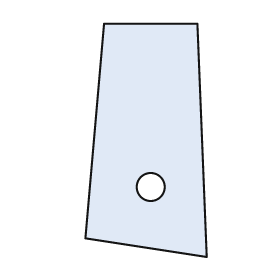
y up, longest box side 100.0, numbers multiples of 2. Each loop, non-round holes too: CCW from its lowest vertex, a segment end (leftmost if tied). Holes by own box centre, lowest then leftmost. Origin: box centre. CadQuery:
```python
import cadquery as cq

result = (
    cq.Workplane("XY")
    .moveTo(26.0, -50.0)
    .lineTo(22.0, 50.0)
    .lineTo(-18.0, 50.0)
    .lineTo(-26.0, -42.0)
    .close()
    .moveTo(2.0, -20.0)
    .circle(6.0)
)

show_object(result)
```